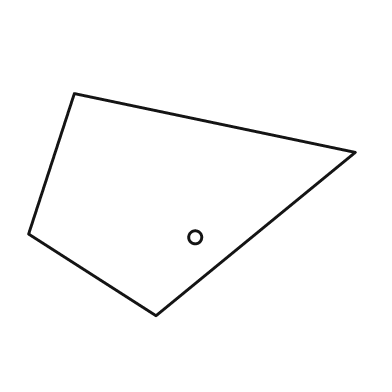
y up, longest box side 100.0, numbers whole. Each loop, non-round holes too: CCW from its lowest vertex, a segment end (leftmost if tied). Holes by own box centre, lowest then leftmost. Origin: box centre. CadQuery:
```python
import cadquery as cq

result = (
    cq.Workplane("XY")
    .moveTo(-11.0, -34.0)
    .lineTo(50.0, 16.0)
    .lineTo(-36.0, 34.0)
    .lineTo(-50.0, -9.0)
    .close()
    .moveTo(1.0, -10.0)
    .circle(2.0)
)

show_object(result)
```